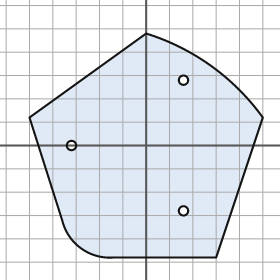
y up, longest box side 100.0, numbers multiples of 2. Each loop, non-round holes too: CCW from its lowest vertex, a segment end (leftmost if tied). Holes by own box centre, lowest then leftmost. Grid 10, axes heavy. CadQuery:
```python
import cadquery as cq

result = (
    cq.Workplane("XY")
    .moveTo(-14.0, -48.0)
    .lineTo(30.0, -48.0)
    .lineTo(50.0, 12.0)
    .threePointArc((28.0, 34.0), (0.0, 48.0))
    .lineTo(-50.0, 12.0)
    .lineTo(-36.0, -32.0)
    .threePointArc((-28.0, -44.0), (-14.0, -48.0))
    .close()
    .moveTo(16.0, -28.0)
    .circle(2.0)
    .moveTo(-32.0, 0.0)
    .circle(2.0)
    .moveTo(16.0, 28.0)
    .circle(2.0)
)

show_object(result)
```